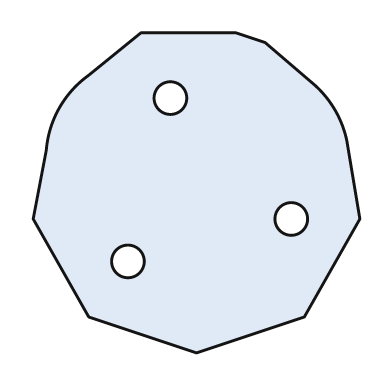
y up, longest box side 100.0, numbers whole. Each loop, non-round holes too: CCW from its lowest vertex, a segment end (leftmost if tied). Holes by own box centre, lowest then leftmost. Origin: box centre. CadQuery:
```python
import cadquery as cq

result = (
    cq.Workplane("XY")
    .moveTo(0.0, -49.0)
    .lineTo(33.0, -38.0)
    .lineTo(50.0, -8.0)
    .lineTo(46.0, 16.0)
    .threePointArc((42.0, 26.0), (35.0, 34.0))
    .lineTo(21.0, 46.0)
    .lineTo(12.0, 49.0)
    .lineTo(-17.0, 49.0)
    .lineTo(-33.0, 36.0)
    .threePointArc((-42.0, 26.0), (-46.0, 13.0))
    .lineTo(-50.0, -8.0)
    .lineTo(-33.0, -38.0)
    .close()
    .moveTo(-21.0, -21.0)
    .circle(5.0)
    .moveTo(29.0, -8.0)
    .circle(5.0)
    .moveTo(-8.0, 29.0)
    .circle(5.0)
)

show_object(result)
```